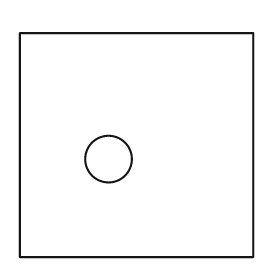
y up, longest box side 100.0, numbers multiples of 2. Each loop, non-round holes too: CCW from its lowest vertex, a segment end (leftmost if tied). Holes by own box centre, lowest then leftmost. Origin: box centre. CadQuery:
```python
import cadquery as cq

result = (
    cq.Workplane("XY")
    .moveTo(-50.0, -48.0)
    .lineTo(50.0, -48.0)
    .lineTo(50.0, 48.0)
    .lineTo(-50.0, 48.0)
    .close()
    .moveTo(-12.0, -6.0)
    .circle(10.0)
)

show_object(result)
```